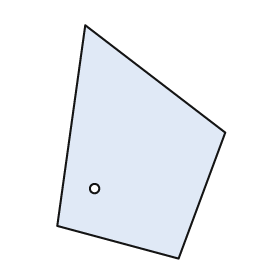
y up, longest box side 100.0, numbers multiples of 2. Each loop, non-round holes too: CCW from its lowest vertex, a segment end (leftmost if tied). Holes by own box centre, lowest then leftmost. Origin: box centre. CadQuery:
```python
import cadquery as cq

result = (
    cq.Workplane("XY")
    .moveTo(16.0, -50.0)
    .lineTo(36.0, 4.0)
    .lineTo(-24.0, 50.0)
    .lineTo(-36.0, -36.0)
    .close()
    .moveTo(-20.0, -20.0)
    .circle(2.0)
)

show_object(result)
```